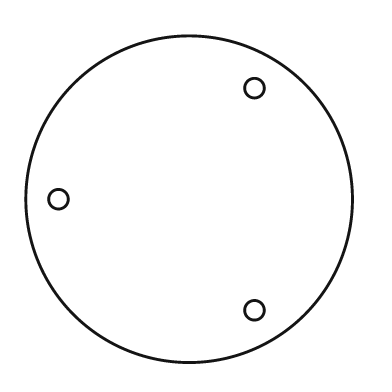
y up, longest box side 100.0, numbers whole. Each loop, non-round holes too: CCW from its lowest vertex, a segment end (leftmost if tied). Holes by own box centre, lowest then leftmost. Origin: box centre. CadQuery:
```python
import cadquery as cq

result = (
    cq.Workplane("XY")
    .moveTo(0.0, 0.0)
    .circle(50.0)
    .moveTo(20.0, -34.0)
    .circle(3.0)
    .moveTo(-40.0, 0.0)
    .circle(3.0)
    .moveTo(20.0, 34.0)
    .circle(3.0)
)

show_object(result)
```